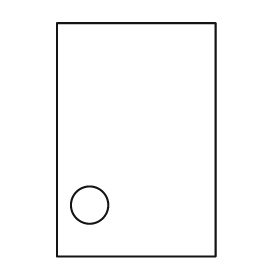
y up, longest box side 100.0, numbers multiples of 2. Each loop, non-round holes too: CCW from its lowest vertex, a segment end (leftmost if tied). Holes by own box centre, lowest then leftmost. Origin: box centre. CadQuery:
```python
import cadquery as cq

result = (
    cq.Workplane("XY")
    .moveTo(-34.0, -50.0)
    .lineTo(34.0, -50.0)
    .lineTo(34.0, 50.0)
    .lineTo(-34.0, 50.0)
    .close()
    .moveTo(-20.0, -28.0)
    .circle(8.0)
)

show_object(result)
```